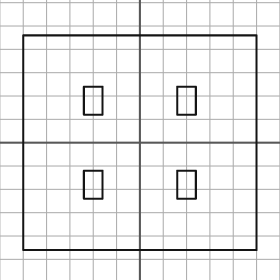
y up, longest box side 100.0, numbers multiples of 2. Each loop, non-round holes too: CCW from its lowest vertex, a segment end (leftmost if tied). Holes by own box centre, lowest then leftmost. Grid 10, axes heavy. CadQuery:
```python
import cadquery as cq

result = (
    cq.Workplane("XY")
    .moveTo(-50.0, -46.0)
    .lineTo(50.0, -46.0)
    .lineTo(50.0, 46.0)
    .lineTo(-50.0, 46.0)
    .close()
    .moveTo(-24.0, -24.0)
    .lineTo(-16.0, -24.0)
    .lineTo(-16.0, -12.0)
    .lineTo(-24.0, -12.0)
    .close()
    .moveTo(16.0, -24.0)
    .lineTo(24.0, -24.0)
    .lineTo(24.0, -12.0)
    .lineTo(16.0, -12.0)
    .close()
    .moveTo(-24.0, 12.0)
    .lineTo(-16.0, 12.0)
    .lineTo(-16.0, 24.0)
    .lineTo(-24.0, 24.0)
    .close()
    .moveTo(16.0, 12.0)
    .lineTo(24.0, 12.0)
    .lineTo(24.0, 24.0)
    .lineTo(16.0, 24.0)
    .close()
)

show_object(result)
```